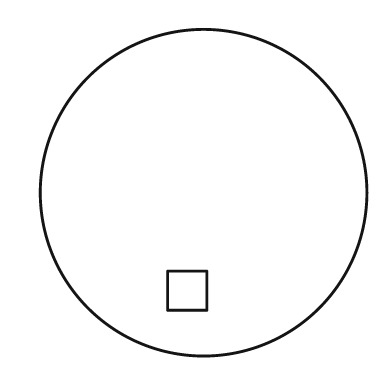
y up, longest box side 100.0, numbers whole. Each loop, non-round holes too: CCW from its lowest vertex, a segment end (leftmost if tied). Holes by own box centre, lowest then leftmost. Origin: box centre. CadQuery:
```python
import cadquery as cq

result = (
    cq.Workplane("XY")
    .moveTo(0.0, 0.0)
    .circle(50.0)
    .moveTo(-11.0, -36.0)
    .lineTo(1.0, -36.0)
    .lineTo(1.0, -24.0)
    .lineTo(-11.0, -24.0)
    .close()
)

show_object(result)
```